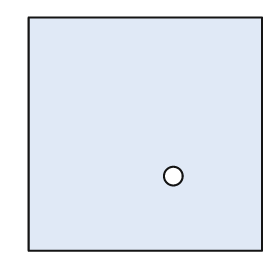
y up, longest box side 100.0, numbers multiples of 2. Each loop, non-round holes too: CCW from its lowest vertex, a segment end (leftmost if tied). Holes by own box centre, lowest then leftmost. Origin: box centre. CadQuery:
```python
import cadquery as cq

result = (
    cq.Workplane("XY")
    .moveTo(-50.0, -50.0)
    .lineTo(50.0, -50.0)
    .lineTo(50.0, 50.0)
    .lineTo(-50.0, 50.0)
    .close()
    .moveTo(12.0, -18.0)
    .circle(4.0)
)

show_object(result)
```